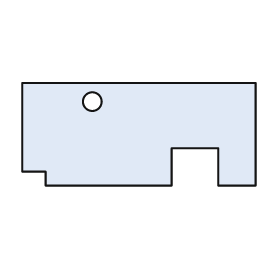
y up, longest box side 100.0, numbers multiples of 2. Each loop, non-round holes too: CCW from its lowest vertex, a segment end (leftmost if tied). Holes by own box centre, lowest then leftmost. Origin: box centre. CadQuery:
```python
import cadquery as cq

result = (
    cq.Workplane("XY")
    .moveTo(-40.0, -22.0)
    .lineTo(14.0, -22.0)
    .lineTo(14.0, -6.0)
    .lineTo(34.0, -6.0)
    .lineTo(34.0, -22.0)
    .lineTo(50.0, -22.0)
    .lineTo(50.0, 22.0)
    .lineTo(-50.0, 22.0)
    .lineTo(-50.0, -16.0)
    .lineTo(-40.0, -16.0)
    .close()
    .moveTo(-20.0, 14.0)
    .circle(4.0)
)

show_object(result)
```